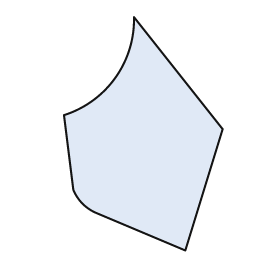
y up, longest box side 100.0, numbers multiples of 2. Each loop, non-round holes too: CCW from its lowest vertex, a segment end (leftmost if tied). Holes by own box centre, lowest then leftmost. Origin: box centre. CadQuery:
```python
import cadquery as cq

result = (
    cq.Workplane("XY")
    .moveTo(18.0, -50.0)
    .lineTo(34.0, 2.0)
    .lineTo(-4.0, 50.0)
    .threePointArc((-12.0, 24.0), (-34.0, 8.0))
    .lineTo(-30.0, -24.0)
    .threePointArc((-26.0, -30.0), (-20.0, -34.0))
    .close()
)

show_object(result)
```